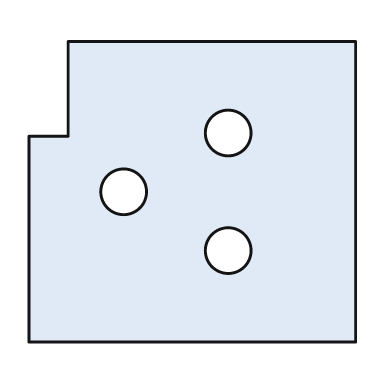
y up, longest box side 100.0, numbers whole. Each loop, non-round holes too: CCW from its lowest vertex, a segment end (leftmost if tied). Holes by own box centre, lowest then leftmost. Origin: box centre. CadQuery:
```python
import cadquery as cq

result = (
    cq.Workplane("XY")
    .moveTo(-50.0, -46.0)
    .lineTo(50.0, -46.0)
    .lineTo(50.0, 46.0)
    .lineTo(-38.0, 46.0)
    .lineTo(-38.0, 17.0)
    .lineTo(-50.0, 17.0)
    .close()
    .moveTo(11.0, -18.0)
    .circle(7.0)
    .moveTo(-21.0, 0.0)
    .circle(7.0)
    .moveTo(11.0, 18.0)
    .circle(7.0)
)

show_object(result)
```